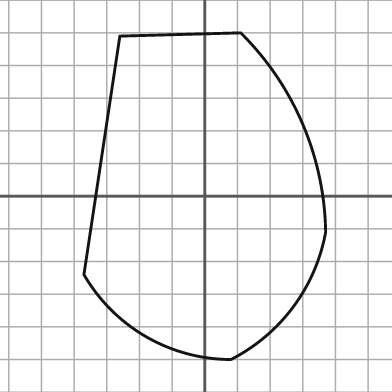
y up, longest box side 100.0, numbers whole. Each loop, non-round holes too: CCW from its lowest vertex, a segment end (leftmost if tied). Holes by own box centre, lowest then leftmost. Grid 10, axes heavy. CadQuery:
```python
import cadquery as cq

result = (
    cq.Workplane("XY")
    .moveTo(8.0, -50.0)
    .threePointArc((27.0, -34.0), (37.0, -11.0))
    .threePointArc((30.0, 22.0), (11.0, 50.0))
    .lineTo(-26.0, 49.0)
    .lineTo(-37.0, -24.0)
    .threePointArc((-18.0, -43.0), (8.0, -50.0))
    .close()
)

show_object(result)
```